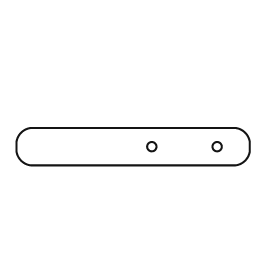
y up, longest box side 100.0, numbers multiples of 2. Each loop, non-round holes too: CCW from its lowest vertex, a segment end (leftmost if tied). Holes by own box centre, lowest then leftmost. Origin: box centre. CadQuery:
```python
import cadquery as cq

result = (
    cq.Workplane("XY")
    .moveTo(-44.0, -8.0)
    .lineTo(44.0, -8.0)
    .threePointArc((48.0, -6.0), (50.0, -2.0))
    .lineTo(50.0, 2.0)
    .threePointArc((48.0, 6.0), (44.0, 8.0))
    .lineTo(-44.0, 8.0)
    .threePointArc((-48.0, 6.0), (-50.0, 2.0))
    .lineTo(-50.0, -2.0)
    .threePointArc((-48.0, -6.0), (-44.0, -8.0))
    .close()
    .moveTo(8.0, 0.0)
    .circle(2.0)
    .moveTo(36.0, 0.0)
    .circle(2.0)
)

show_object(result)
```